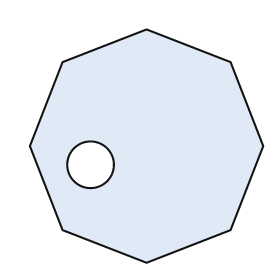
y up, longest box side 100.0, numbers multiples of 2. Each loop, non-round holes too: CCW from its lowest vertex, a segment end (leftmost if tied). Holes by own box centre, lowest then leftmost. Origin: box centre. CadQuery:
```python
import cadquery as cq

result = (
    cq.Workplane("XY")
    .moveTo(0.0, -50.0)
    .lineTo(36.0, -36.0)
    .lineTo(50.0, 0.0)
    .lineTo(36.0, 36.0)
    .lineTo(0.0, 50.0)
    .lineTo(-36.0, 36.0)
    .lineTo(-50.0, 0.0)
    .lineTo(-36.0, -36.0)
    .close()
    .moveTo(-24.0, -8.0)
    .circle(10.0)
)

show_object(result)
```